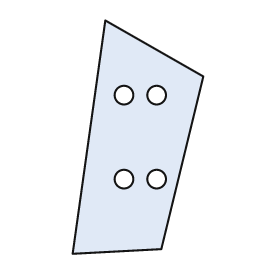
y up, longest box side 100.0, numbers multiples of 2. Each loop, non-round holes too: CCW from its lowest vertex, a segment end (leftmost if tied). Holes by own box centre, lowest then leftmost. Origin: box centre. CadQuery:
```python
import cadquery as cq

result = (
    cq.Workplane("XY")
    .moveTo(-28.0, -50.0)
    .lineTo(10.0, -48.0)
    .lineTo(28.0, 26.0)
    .lineTo(-14.0, 50.0)
    .close()
    .moveTo(-6.0, -18.0)
    .circle(4.0)
    .moveTo(8.0, -18.0)
    .circle(4.0)
    .moveTo(-6.0, 18.0)
    .circle(4.0)
    .moveTo(8.0, 18.0)
    .circle(4.0)
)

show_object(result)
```